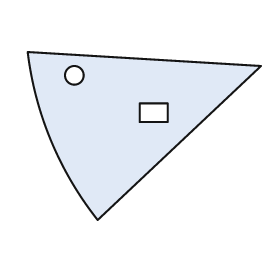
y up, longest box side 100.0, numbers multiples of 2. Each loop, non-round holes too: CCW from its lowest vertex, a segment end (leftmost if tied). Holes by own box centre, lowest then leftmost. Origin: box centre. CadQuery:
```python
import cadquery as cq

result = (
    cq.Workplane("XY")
    .moveTo(-20.0, -36.0)
    .lineTo(50.0, 30.0)
    .lineTo(-50.0, 36.0)
    .threePointArc((-40.0, -2.0), (-20.0, -36.0))
    .close()
    .moveTo(-2.0, 6.0)
    .lineTo(10.0, 6.0)
    .lineTo(10.0, 14.0)
    .lineTo(-2.0, 14.0)
    .close()
    .moveTo(-30.0, 26.0)
    .circle(4.0)
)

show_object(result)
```